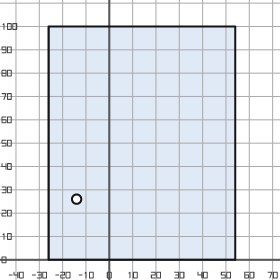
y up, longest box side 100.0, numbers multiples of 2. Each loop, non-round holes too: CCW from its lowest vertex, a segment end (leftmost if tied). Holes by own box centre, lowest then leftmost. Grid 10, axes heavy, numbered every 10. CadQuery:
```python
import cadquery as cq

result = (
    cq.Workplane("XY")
    .moveTo(-26.0, 0.0)
    .lineTo(54.0, 0.0)
    .lineTo(54.0, 100.0)
    .lineTo(-26.0, 100.0)
    .close()
    .moveTo(-14.0, 26.0)
    .circle(2.0)
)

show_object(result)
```